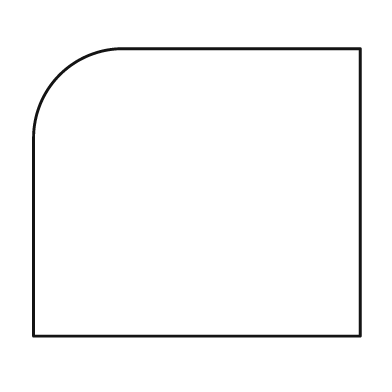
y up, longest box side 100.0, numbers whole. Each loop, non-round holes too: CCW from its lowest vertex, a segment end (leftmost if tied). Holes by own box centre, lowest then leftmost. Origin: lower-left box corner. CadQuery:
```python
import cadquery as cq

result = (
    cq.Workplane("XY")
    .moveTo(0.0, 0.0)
    .lineTo(100.0, 0.0)
    .lineTo(100.0, 88.0)
    .lineTo(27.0, 88.0)
    .threePointArc((8.0, 80.0), (0.0, 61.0))
    .close()
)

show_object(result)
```